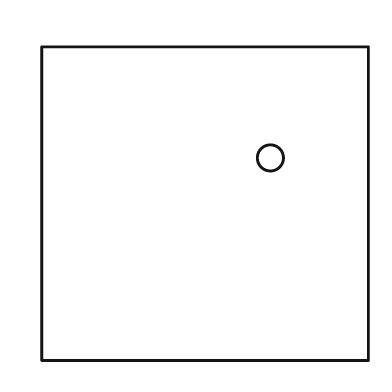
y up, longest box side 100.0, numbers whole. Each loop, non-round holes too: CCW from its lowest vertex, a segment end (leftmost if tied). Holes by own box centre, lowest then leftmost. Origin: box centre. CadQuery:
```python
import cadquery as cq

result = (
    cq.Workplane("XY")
    .moveTo(-50.0, -48.0)
    .lineTo(50.0, -48.0)
    .lineTo(50.0, 48.0)
    .lineTo(-50.0, 48.0)
    .close()
    .moveTo(20.0, 14.0)
    .circle(4.0)
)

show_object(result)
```